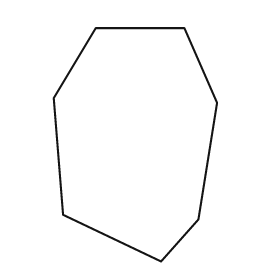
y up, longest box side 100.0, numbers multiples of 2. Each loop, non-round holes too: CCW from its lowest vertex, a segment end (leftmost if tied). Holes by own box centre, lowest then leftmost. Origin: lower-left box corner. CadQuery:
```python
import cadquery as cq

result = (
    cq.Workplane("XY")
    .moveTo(46.0, 0.0)
    .lineTo(62.0, 18.0)
    .lineTo(70.0, 68.0)
    .lineTo(56.0, 100.0)
    .lineTo(18.0, 100.0)
    .lineTo(0.0, 70.0)
    .lineTo(4.0, 20.0)
    .close()
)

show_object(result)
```